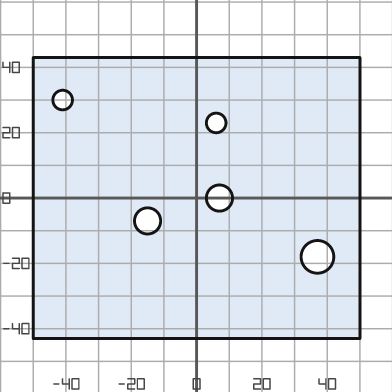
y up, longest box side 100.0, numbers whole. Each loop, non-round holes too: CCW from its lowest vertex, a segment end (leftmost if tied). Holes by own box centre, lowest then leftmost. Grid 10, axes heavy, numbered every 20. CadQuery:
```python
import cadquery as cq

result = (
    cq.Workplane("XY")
    .moveTo(-50.0, -43.0)
    .lineTo(50.0, -43.0)
    .lineTo(50.0, 43.0)
    .lineTo(-50.0, 43.0)
    .close()
    .moveTo(37.0, -18.0)
    .circle(5.0)
    .moveTo(-15.0, -7.0)
    .circle(4.0)
    .moveTo(7.0, 0.0)
    .circle(4.0)
    .moveTo(6.0, 23.0)
    .circle(3.0)
    .moveTo(-41.0, 30.0)
    .circle(3.0)
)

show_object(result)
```